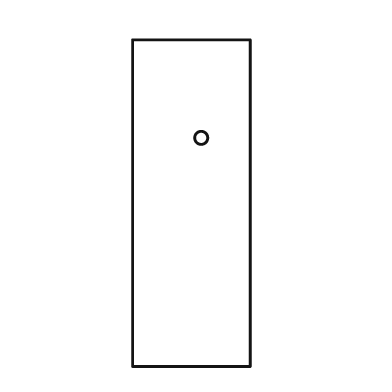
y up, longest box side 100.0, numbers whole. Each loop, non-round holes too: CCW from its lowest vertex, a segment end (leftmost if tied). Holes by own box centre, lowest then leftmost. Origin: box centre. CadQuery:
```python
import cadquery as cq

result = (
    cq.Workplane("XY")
    .moveTo(-18.0, -50.0)
    .lineTo(18.0, -50.0)
    .lineTo(18.0, 50.0)
    .lineTo(-18.0, 50.0)
    .close()
    .moveTo(3.0, 20.0)
    .circle(2.0)
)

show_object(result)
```